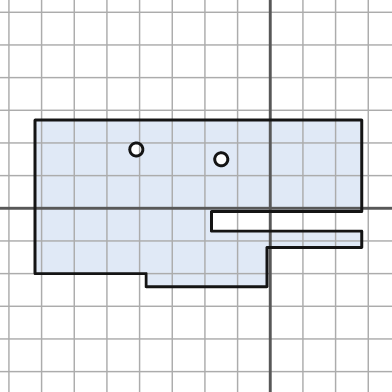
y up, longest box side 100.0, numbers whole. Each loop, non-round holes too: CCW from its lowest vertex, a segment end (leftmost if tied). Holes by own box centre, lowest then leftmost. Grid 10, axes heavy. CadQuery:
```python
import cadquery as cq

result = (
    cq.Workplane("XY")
    .moveTo(-38.0, -24.0)
    .lineTo(-1.0, -24.0)
    .lineTo(-1.0, -12.0)
    .lineTo(28.0, -12.0)
    .lineTo(28.0, -7.0)
    .lineTo(-18.0, -7.0)
    .lineTo(-18.0, -1.0)
    .lineTo(28.0, -1.0)
    .lineTo(28.0, 27.0)
    .lineTo(-72.0, 27.0)
    .lineTo(-72.0, -20.0)
    .lineTo(-38.0, -20.0)
    .close()
    .moveTo(-15.0, 15.0)
    .circle(2.0)
    .moveTo(-41.0, 18.0)
    .circle(2.0)
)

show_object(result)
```